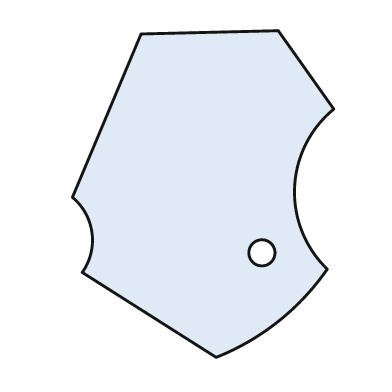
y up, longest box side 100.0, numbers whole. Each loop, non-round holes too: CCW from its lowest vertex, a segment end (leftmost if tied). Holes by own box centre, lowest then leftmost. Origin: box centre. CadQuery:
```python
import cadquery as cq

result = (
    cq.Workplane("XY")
    .moveTo(4.0, -50.0)
    .threePointArc((23.0, -39.0), (38.0, -23.0))
    .threePointArc((28.0, 2.0), (40.0, 26.0))
    .lineTo(23.0, 50.0)
    .lineTo(-19.0, 49.0)
    .lineTo(-40.0, -1.0)
    .threePointArc((-34.0, -12.0), (-37.0, -24.0))
    .close()
    .moveTo(18.0, -18.0)
    .circle(4.0)
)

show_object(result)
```